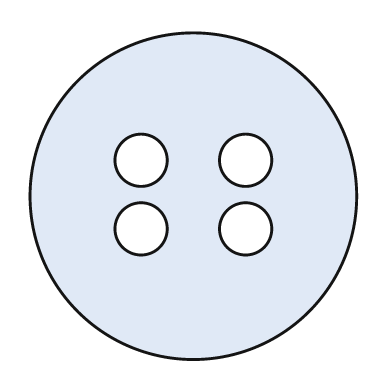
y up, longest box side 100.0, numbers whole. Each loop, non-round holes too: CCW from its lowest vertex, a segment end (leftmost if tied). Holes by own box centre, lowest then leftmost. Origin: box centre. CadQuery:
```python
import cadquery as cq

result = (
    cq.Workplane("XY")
    .moveTo(0.0, 0.0)
    .circle(50.0)
    .moveTo(-16.0, -10.0)
    .circle(8.0)
    .moveTo(16.0, -10.0)
    .circle(8.0)
    .moveTo(-16.0, 11.0)
    .circle(8.0)
    .moveTo(16.0, 11.0)
    .circle(8.0)
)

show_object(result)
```